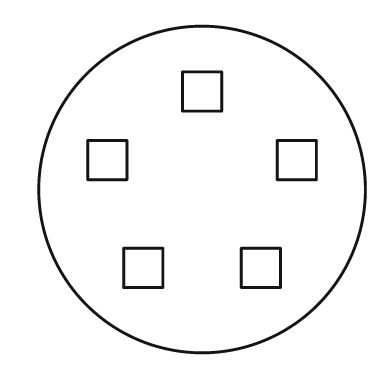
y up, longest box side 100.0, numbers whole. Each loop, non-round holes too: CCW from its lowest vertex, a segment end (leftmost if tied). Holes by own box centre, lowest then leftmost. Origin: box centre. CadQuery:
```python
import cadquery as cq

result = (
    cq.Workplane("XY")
    .moveTo(0.0, 0.0)
    .circle(50.0)
    .moveTo(-24.0, -30.0)
    .lineTo(-12.0, -30.0)
    .lineTo(-12.0, -18.0)
    .lineTo(-24.0, -18.0)
    .close()
    .moveTo(12.0, -30.0)
    .lineTo(24.0, -30.0)
    .lineTo(24.0, -18.0)
    .lineTo(12.0, -18.0)
    .close()
    .moveTo(-35.0, 3.0)
    .lineTo(-23.0, 3.0)
    .lineTo(-23.0, 15.0)
    .lineTo(-35.0, 15.0)
    .close()
    .moveTo(23.0, 3.0)
    .lineTo(35.0, 3.0)
    .lineTo(35.0, 15.0)
    .lineTo(23.0, 15.0)
    .close()
    .moveTo(-6.0, 24.0)
    .lineTo(6.0, 24.0)
    .lineTo(6.0, 36.0)
    .lineTo(-6.0, 36.0)
    .close()
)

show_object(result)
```